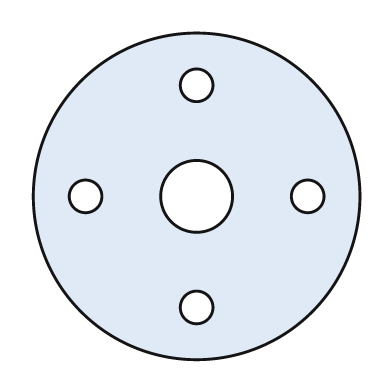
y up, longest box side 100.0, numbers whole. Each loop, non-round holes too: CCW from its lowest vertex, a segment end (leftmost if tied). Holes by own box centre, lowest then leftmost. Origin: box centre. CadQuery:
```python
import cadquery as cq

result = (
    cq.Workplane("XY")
    .moveTo(0.0, 0.0)
    .circle(50.0)
    .moveTo(0.0, -34.0)
    .circle(5.0)
    .moveTo(-34.0, 0.0)
    .circle(5.0)
    .moveTo(0.0, 0.0)
    .circle(11.0)
    .moveTo(34.0, 0.0)
    .circle(5.0)
    .moveTo(0.0, 34.0)
    .circle(5.0)
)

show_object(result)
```